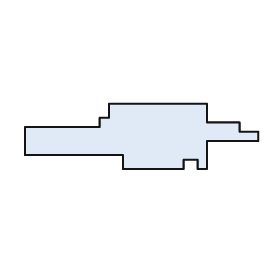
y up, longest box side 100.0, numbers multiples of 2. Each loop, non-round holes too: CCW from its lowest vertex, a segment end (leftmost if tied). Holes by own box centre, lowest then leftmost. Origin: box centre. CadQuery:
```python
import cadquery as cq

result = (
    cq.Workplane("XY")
    .moveTo(-8.0, -14.0)
    .lineTo(18.0, -14.0)
    .lineTo(18.0, -10.0)
    .lineTo(24.0, -10.0)
    .lineTo(24.0, -14.0)
    .lineTo(28.0, -14.0)
    .lineTo(28.0, -2.0)
    .lineTo(50.0, -2.0)
    .lineTo(50.0, 2.0)
    .lineTo(42.0, 2.0)
    .lineTo(42.0, 6.0)
    .lineTo(28.0, 6.0)
    .lineTo(28.0, 14.0)
    .lineTo(-14.0, 14.0)
    .lineTo(-14.0, 8.0)
    .lineTo(-18.0, 8.0)
    .lineTo(-18.0, 4.0)
    .lineTo(-50.0, 4.0)
    .lineTo(-50.0, -8.0)
    .lineTo(-8.0, -8.0)
    .close()
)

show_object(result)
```